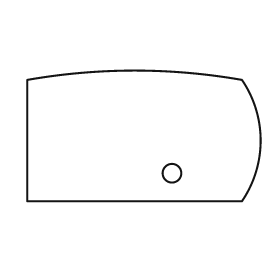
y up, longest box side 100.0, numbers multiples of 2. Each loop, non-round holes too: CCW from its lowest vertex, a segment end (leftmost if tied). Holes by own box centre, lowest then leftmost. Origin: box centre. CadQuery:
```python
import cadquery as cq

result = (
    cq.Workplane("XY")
    .moveTo(-50.0, -28.0)
    .lineTo(42.0, -28.0)
    .threePointArc((50.0, -2.0), (42.0, 24.0))
    .threePointArc((-4.0, 28.0), (-50.0, 24.0))
    .close()
    .moveTo(12.0, -16.0)
    .circle(4.0)
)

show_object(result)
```